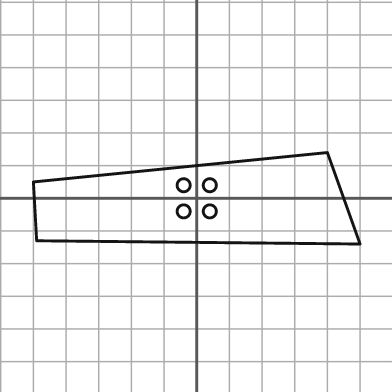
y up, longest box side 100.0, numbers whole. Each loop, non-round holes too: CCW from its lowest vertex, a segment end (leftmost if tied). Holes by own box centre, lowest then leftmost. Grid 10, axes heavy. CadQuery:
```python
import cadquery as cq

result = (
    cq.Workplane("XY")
    .moveTo(50.0, -14.0)
    .lineTo(40.0, 14.0)
    .lineTo(-50.0, 5.0)
    .lineTo(-49.0, -13.0)
    .close()
    .moveTo(-4.0, -4.0)
    .circle(2.0)
    .moveTo(4.0, -4.0)
    .circle(2.0)
    .moveTo(-4.0, 4.0)
    .circle(2.0)
    .moveTo(4.0, 4.0)
    .circle(2.0)
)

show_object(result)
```